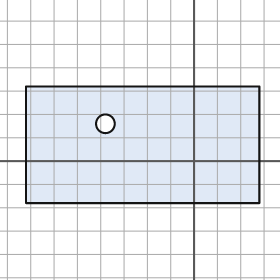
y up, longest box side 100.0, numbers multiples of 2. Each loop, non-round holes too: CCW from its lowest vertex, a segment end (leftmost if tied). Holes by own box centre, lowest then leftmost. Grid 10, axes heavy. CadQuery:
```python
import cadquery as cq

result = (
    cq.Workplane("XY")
    .moveTo(-72.0, -18.0)
    .lineTo(28.0, -18.0)
    .lineTo(28.0, 32.0)
    .lineTo(-72.0, 32.0)
    .close()
    .moveTo(-38.0, 16.0)
    .circle(4.0)
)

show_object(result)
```